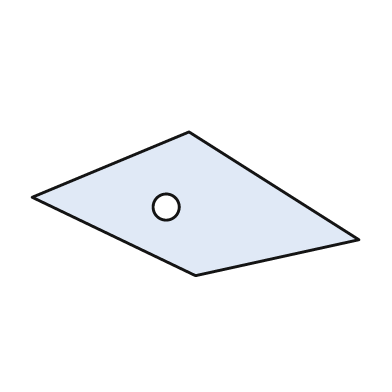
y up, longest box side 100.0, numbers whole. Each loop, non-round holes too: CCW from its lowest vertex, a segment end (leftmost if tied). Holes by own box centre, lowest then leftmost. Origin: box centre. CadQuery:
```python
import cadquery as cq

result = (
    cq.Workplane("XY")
    .moveTo(0.0, -22.0)
    .lineTo(50.0, -11.0)
    .lineTo(-2.0, 22.0)
    .lineTo(-50.0, 2.0)
    .close()
    .moveTo(-9.0, -1.0)
    .circle(4.0)
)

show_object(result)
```